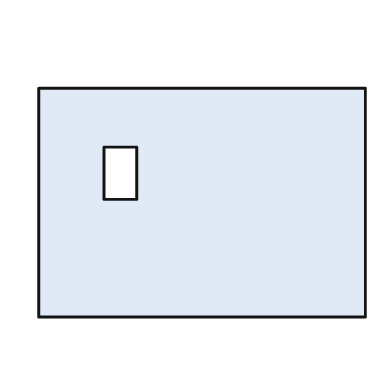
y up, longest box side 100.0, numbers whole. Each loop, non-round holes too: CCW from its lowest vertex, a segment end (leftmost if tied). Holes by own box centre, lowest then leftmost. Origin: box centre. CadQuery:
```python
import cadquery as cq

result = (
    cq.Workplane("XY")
    .moveTo(-50.0, -35.0)
    .lineTo(50.0, -35.0)
    .lineTo(50.0, 35.0)
    .lineTo(-50.0, 35.0)
    .close()
    .moveTo(-30.0, 1.0)
    .lineTo(-20.0, 1.0)
    .lineTo(-20.0, 17.0)
    .lineTo(-30.0, 17.0)
    .close()
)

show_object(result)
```